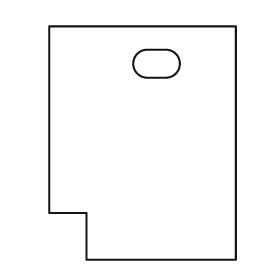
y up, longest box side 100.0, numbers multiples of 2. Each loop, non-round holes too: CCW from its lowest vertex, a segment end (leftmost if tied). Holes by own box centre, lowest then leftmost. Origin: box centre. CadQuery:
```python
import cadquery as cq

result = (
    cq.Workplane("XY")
    .moveTo(-24.0, -50.0)
    .lineTo(40.0, -50.0)
    .lineTo(40.0, 50.0)
    .lineTo(-40.0, 50.0)
    .lineTo(-40.0, -30.0)
    .lineTo(-24.0, -30.0)
    .close()
    .moveTo(2.0, 28.0)
    .lineTo(10.0, 28.0)
    .threePointArc((16.0, 34.0), (10.0, 40.0))
    .lineTo(2.0, 40.0)
    .threePointArc((-4.0, 34.0), (2.0, 28.0))
    .close()
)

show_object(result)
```